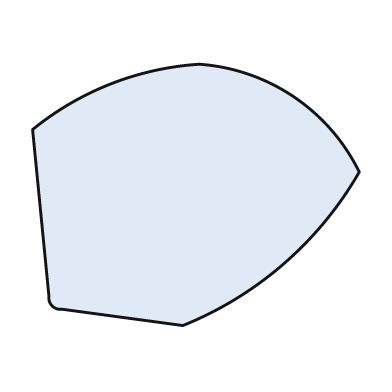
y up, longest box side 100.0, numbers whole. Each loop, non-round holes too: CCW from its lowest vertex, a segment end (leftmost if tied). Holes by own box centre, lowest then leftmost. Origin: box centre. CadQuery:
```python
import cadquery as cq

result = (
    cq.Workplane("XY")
    .moveTo(-4.0, -40.0)
    .threePointArc((27.0, -21.0), (50.0, 7.0))
    .threePointArc((30.0, 30.0), (1.0, 40.0))
    .threePointArc((-26.0, 34.0), (-50.0, 20.0))
    .lineTo(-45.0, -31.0)
    .threePointArc((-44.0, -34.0), (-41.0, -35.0))
    .close()
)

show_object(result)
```